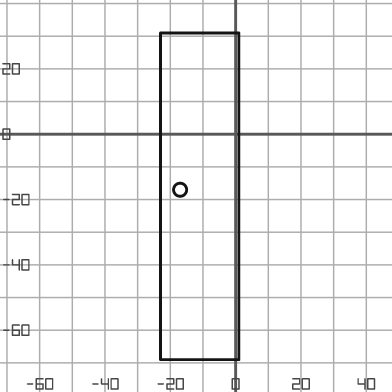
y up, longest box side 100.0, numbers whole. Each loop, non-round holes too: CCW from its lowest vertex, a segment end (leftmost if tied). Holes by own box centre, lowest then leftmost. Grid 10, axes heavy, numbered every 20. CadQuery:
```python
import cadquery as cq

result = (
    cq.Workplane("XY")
    .moveTo(-23.0, -69.0)
    .lineTo(1.0, -69.0)
    .lineTo(1.0, 31.0)
    .lineTo(-23.0, 31.0)
    .close()
    .moveTo(-17.0, -17.0)
    .circle(2.0)
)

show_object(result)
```